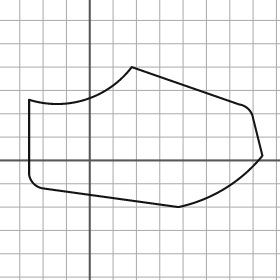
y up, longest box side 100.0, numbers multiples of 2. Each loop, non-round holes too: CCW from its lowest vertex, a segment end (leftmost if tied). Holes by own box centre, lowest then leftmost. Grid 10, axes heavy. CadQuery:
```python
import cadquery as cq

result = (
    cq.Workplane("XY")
    .moveTo(38.0, -20.0)
    .threePointArc((58.0, -12.0), (74.0, 2.0))
    .lineTo(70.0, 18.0)
    .threePointArc((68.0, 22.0), (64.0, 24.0))
    .lineTo(18.0, 40.0)
    .threePointArc((-2.0, 26.0), (-26.0, 26.0))
    .lineTo(-26.0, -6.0)
    .threePointArc((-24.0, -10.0), (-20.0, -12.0))
    .close()
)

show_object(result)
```